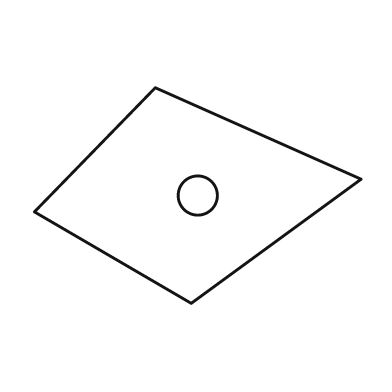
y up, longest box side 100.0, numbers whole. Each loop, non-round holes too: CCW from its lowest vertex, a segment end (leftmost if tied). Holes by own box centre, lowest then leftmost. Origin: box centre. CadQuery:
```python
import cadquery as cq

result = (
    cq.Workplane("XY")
    .moveTo(-2.0, -33.0)
    .lineTo(50.0, 5.0)
    .lineTo(-13.0, 33.0)
    .lineTo(-50.0, -5.0)
    .close()
    .moveTo(0.0, 0.0)
    .circle(6.0)
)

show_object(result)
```